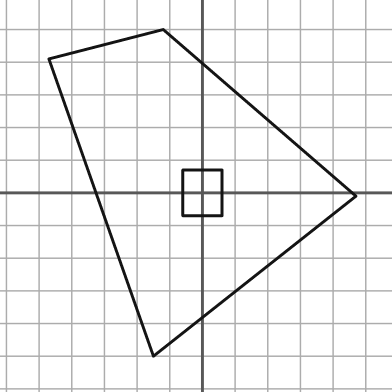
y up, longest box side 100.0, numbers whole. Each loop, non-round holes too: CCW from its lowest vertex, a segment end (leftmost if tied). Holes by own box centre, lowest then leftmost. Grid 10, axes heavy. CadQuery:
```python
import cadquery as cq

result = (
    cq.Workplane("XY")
    .moveTo(-15.0, -50.0)
    .lineTo(47.0, -1.0)
    .lineTo(-12.0, 50.0)
    .lineTo(-47.0, 41.0)
    .close()
    .moveTo(-6.0, -7.0)
    .lineTo(6.0, -7.0)
    .lineTo(6.0, 7.0)
    .lineTo(-6.0, 7.0)
    .close()
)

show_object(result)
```